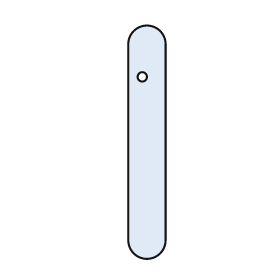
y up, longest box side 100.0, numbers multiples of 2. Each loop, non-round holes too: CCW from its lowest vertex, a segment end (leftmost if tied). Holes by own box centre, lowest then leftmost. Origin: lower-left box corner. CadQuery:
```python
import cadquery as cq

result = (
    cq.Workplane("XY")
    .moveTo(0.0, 8.0)
    .threePointArc((8.0, 0.0), (16.0, 8.0))
    .lineTo(16.0, 92.0)
    .threePointArc((8.0, 100.0), (0.0, 92.0))
    .close()
    .moveTo(6.0, 78.0)
    .circle(2.0)
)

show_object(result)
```